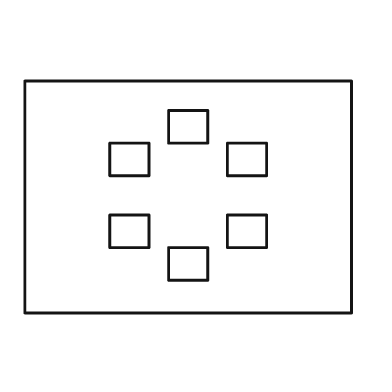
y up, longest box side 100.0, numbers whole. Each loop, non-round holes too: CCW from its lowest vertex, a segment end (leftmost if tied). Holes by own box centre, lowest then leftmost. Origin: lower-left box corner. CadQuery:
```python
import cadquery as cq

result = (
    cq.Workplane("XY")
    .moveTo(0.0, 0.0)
    .lineTo(100.0, 0.0)
    .lineTo(100.0, 71.0)
    .lineTo(0.0, 71.0)
    .close()
    .moveTo(44.0, 10.0)
    .lineTo(56.0, 10.0)
    .lineTo(56.0, 20.0)
    .lineTo(44.0, 20.0)
    .close()
    .moveTo(26.0, 20.0)
    .lineTo(38.0, 20.0)
    .lineTo(38.0, 30.0)
    .lineTo(26.0, 30.0)
    .close()
    .moveTo(62.0, 20.0)
    .lineTo(74.0, 20.0)
    .lineTo(74.0, 30.0)
    .lineTo(62.0, 30.0)
    .close()
    .moveTo(26.0, 42.0)
    .lineTo(38.0, 42.0)
    .lineTo(38.0, 52.0)
    .lineTo(26.0, 52.0)
    .close()
    .moveTo(62.0, 42.0)
    .lineTo(74.0, 42.0)
    .lineTo(74.0, 52.0)
    .lineTo(62.0, 52.0)
    .close()
    .moveTo(44.0, 52.0)
    .lineTo(56.0, 52.0)
    .lineTo(56.0, 62.0)
    .lineTo(44.0, 62.0)
    .close()
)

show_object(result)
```